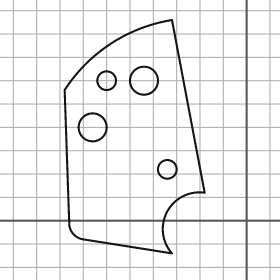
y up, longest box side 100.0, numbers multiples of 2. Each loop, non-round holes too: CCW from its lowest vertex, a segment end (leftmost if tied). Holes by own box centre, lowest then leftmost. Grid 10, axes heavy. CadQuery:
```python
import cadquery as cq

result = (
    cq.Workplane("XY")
    .moveTo(-32.0, -14.0)
    .threePointArc((-34.0, 4.0), (-18.0, 12.0))
    .lineTo(-32.0, 86.0)
    .threePointArc((-58.0, 76.0), (-78.0, 56.0))
    .lineTo(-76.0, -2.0)
    .threePointArc((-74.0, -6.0), (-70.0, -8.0))
    .close()
    .moveTo(-34.0, 22.0)
    .circle(4.0)
    .moveTo(-66.0, 40.0)
    .circle(6.0)
    .moveTo(-60.0, 60.0)
    .circle(4.0)
    .moveTo(-44.0, 60.0)
    .circle(6.0)
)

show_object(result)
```